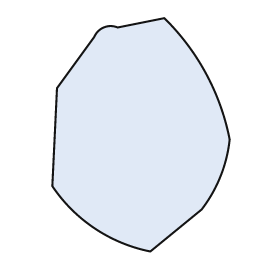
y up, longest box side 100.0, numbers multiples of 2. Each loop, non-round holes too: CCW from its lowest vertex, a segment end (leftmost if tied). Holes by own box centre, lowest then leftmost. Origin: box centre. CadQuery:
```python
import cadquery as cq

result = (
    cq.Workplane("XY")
    .moveTo(4.0, -50.0)
    .lineTo(26.0, -32.0)
    .threePointArc((34.0, -18.0), (38.0, -2.0))
    .threePointArc((28.0, 26.0), (10.0, 50.0))
    .lineTo(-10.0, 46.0)
    .threePointArc((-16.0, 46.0), (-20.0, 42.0))
    .lineTo(-36.0, 20.0)
    .lineTo(-38.0, -22.0)
    .threePointArc((-20.0, -40.0), (4.0, -50.0))
    .close()
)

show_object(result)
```